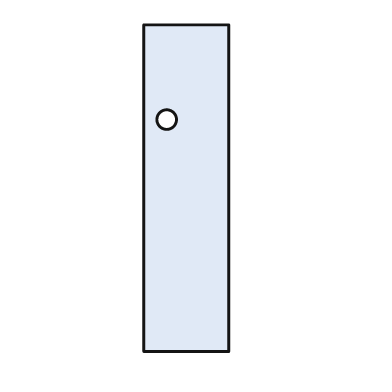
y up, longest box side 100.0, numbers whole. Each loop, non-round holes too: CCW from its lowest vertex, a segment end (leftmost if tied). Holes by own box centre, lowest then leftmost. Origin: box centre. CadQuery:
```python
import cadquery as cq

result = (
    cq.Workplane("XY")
    .moveTo(-13.0, -50.0)
    .lineTo(13.0, -50.0)
    .lineTo(13.0, 50.0)
    .lineTo(-13.0, 50.0)
    .close()
    .moveTo(-6.0, 21.0)
    .circle(3.0)
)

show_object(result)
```